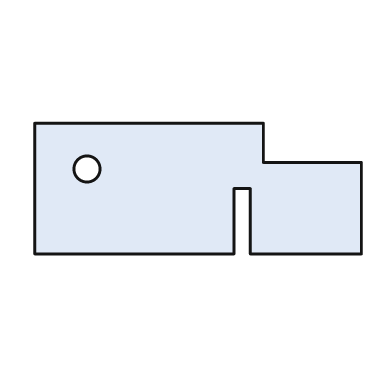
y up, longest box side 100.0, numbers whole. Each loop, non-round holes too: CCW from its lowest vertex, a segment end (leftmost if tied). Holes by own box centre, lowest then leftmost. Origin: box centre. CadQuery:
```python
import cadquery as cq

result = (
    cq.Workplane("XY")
    .moveTo(-50.0, -20.0)
    .lineTo(11.0, -20.0)
    .lineTo(11.0, 0.0)
    .lineTo(16.0, 0.0)
    .lineTo(16.0, -20.0)
    .lineTo(50.0, -20.0)
    .lineTo(50.0, 8.0)
    .lineTo(20.0, 8.0)
    .lineTo(20.0, 20.0)
    .lineTo(-50.0, 20.0)
    .close()
    .moveTo(-34.0, 6.0)
    .circle(4.0)
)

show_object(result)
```